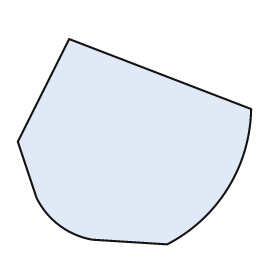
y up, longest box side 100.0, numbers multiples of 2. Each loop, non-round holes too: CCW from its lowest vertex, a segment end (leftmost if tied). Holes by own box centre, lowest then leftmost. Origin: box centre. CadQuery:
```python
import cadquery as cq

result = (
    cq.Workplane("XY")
    .moveTo(14.0, -44.0)
    .threePointArc((40.0, -20.0), (50.0, 14.0))
    .lineTo(-28.0, 44.0)
    .lineTo(-50.0, 0.0)
    .lineTo(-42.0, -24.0)
    .threePointArc((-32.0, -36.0), (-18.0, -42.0))
    .close()
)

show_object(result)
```